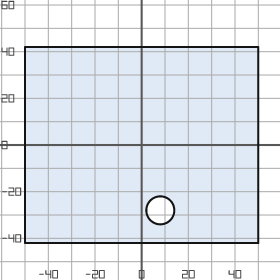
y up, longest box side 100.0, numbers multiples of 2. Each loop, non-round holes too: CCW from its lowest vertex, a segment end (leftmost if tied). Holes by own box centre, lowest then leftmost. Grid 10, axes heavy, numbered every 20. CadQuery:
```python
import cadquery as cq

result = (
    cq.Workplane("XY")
    .moveTo(-50.0, -42.0)
    .lineTo(50.0, -42.0)
    .lineTo(50.0, 42.0)
    .lineTo(-50.0, 42.0)
    .close()
    .moveTo(8.0, -28.0)
    .circle(6.0)
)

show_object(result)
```